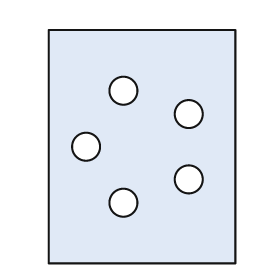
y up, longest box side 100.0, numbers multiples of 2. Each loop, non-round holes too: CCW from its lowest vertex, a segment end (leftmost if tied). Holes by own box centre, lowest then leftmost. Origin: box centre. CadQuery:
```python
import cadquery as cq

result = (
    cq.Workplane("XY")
    .moveTo(-40.0, -50.0)
    .lineTo(40.0, -50.0)
    .lineTo(40.0, 50.0)
    .lineTo(-40.0, 50.0)
    .close()
    .moveTo(-8.0, -24.0)
    .circle(6.0)
    .moveTo(20.0, -14.0)
    .circle(6.0)
    .moveTo(-24.0, 0.0)
    .circle(6.0)
    .moveTo(20.0, 14.0)
    .circle(6.0)
    .moveTo(-8.0, 24.0)
    .circle(6.0)
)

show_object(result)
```